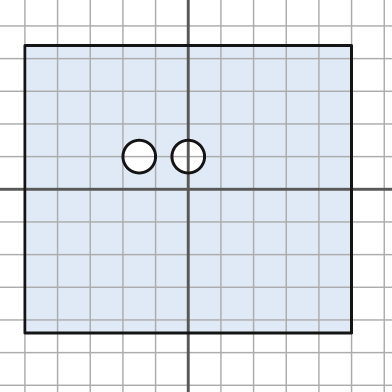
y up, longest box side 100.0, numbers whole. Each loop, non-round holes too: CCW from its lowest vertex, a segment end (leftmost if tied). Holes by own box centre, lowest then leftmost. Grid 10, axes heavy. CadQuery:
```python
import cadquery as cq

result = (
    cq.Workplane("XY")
    .moveTo(-50.0, -44.0)
    .lineTo(50.0, -44.0)
    .lineTo(50.0, 44.0)
    .lineTo(-50.0, 44.0)
    .close()
    .moveTo(-15.0, 10.0)
    .circle(5.0)
    .moveTo(0.0, 10.0)
    .circle(5.0)
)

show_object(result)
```